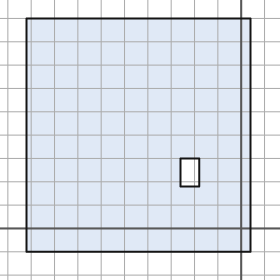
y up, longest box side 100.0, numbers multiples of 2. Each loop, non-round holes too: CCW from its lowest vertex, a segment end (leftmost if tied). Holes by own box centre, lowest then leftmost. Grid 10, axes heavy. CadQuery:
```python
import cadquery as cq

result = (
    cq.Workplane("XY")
    .moveTo(-92.0, -10.0)
    .lineTo(4.0, -10.0)
    .lineTo(4.0, 90.0)
    .lineTo(-92.0, 90.0)
    .close()
    .moveTo(-26.0, 18.0)
    .lineTo(-18.0, 18.0)
    .lineTo(-18.0, 30.0)
    .lineTo(-26.0, 30.0)
    .close()
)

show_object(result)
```